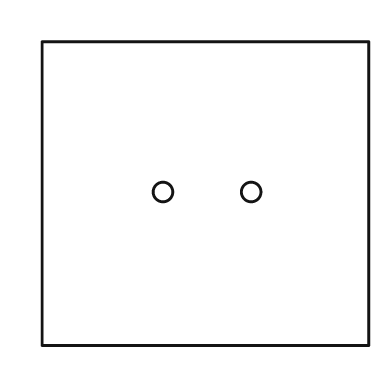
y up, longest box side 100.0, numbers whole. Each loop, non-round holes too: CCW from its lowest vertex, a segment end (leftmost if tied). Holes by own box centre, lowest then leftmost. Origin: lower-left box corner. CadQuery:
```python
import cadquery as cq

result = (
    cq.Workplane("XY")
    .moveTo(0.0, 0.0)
    .lineTo(100.0, 0.0)
    .lineTo(100.0, 93.0)
    .lineTo(0.0, 93.0)
    .close()
    .moveTo(37.0, 47.0)
    .circle(3.0)
    .moveTo(64.0, 47.0)
    .circle(3.0)
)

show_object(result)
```